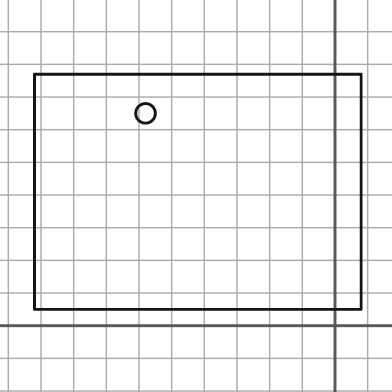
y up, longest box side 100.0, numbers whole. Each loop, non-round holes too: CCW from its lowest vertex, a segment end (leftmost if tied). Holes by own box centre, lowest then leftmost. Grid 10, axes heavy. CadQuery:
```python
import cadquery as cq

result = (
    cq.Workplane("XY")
    .moveTo(-92.0, 5.0)
    .lineTo(8.0, 5.0)
    .lineTo(8.0, 77.0)
    .lineTo(-92.0, 77.0)
    .close()
    .moveTo(-58.0, 65.0)
    .circle(3.0)
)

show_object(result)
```